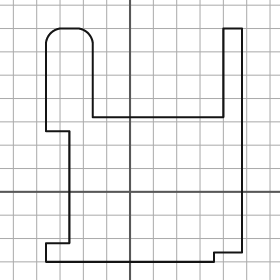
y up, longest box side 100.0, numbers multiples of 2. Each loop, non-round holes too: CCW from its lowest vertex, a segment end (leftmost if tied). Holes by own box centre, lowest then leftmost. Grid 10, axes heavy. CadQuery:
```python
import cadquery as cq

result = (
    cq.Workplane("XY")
    .moveTo(-36.0, -30.0)
    .lineTo(36.0, -30.0)
    .lineTo(36.0, -26.0)
    .lineTo(48.0, -26.0)
    .lineTo(48.0, 70.0)
    .lineTo(40.0, 70.0)
    .lineTo(40.0, 32.0)
    .lineTo(-16.0, 32.0)
    .lineTo(-16.0, 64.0)
    .threePointArc((-18.0, 68.0), (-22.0, 70.0))
    .lineTo(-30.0, 70.0)
    .threePointArc((-34.0, 68.0), (-36.0, 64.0))
    .lineTo(-36.0, 26.0)
    .lineTo(-26.0, 26.0)
    .lineTo(-26.0, -22.0)
    .lineTo(-36.0, -22.0)
    .close()
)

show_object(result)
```